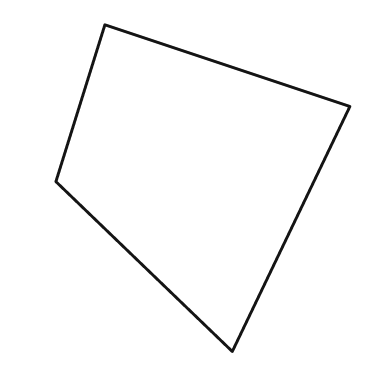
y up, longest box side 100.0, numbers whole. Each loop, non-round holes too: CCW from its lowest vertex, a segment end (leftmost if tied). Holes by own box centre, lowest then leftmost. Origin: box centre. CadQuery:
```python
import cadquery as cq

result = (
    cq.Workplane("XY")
    .moveTo(9.0, -50.0)
    .lineTo(45.0, 25.0)
    .lineTo(-30.0, 50.0)
    .lineTo(-45.0, 2.0)
    .close()
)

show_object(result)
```